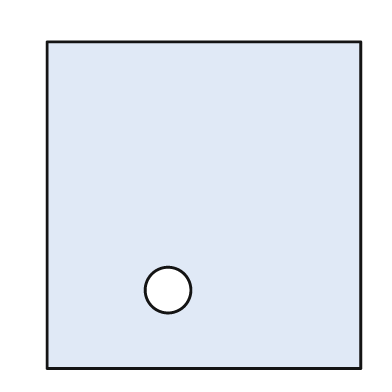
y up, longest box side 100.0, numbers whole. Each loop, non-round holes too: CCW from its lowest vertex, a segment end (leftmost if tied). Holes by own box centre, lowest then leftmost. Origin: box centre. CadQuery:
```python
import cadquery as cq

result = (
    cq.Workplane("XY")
    .moveTo(-48.0, -50.0)
    .lineTo(48.0, -50.0)
    .lineTo(48.0, 50.0)
    .lineTo(-48.0, 50.0)
    .close()
    .moveTo(-11.0, -26.0)
    .circle(7.0)
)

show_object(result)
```